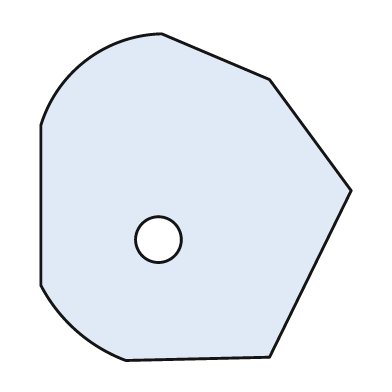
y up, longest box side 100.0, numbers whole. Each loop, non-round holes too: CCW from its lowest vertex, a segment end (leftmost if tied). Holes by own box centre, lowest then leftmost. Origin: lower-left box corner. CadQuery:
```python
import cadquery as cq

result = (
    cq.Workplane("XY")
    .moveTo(26.0, 0.0)
    .lineTo(70.0, 1.0)
    .lineTo(95.0, 52.0)
    .lineTo(70.0, 86.0)
    .lineTo(37.0, 100.0)
    .threePointArc((14.0, 92.0), (0.0, 72.0))
    .lineTo(0.0, 23.0)
    .threePointArc((11.0, 9.0), (26.0, 0.0))
    .close()
    .moveTo(36.0, 37.0)
    .circle(7.0)
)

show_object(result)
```